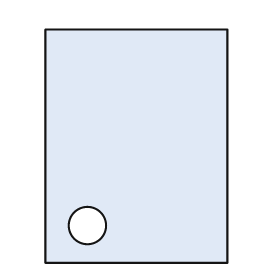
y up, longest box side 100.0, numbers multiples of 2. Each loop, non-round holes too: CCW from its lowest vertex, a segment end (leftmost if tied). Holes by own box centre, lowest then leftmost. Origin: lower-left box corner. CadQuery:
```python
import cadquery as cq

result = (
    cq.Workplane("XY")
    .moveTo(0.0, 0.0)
    .lineTo(78.0, 0.0)
    .lineTo(78.0, 100.0)
    .lineTo(0.0, 100.0)
    .close()
    .moveTo(18.0, 16.0)
    .circle(8.0)
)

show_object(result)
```